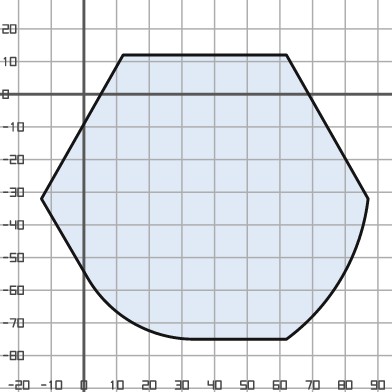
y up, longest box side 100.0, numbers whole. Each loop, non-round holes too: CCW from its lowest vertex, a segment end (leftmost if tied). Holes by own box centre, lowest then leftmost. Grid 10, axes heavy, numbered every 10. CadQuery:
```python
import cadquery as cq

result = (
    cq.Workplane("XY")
    .moveTo(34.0, -75.0)
    .lineTo(62.0, -75.0)
    .threePointArc((79.0, -56.0), (87.0, -32.0))
    .lineTo(62.0, 12.0)
    .lineTo(12.0, 12.0)
    .lineTo(-13.0, -32.0)
    .lineTo(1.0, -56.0)
    .threePointArc((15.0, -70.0), (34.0, -75.0))
    .close()
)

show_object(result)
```